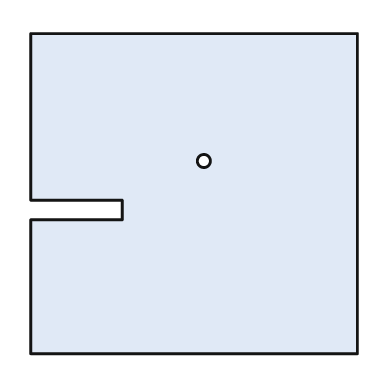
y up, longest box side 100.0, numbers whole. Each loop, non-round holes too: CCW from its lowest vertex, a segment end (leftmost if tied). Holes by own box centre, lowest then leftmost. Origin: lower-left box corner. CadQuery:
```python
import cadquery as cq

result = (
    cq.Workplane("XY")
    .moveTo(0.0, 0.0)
    .lineTo(100.0, 0.0)
    .lineTo(100.0, 98.0)
    .lineTo(0.0, 98.0)
    .lineTo(0.0, 47.0)
    .lineTo(28.0, 47.0)
    .lineTo(28.0, 41.0)
    .lineTo(0.0, 41.0)
    .close()
    .moveTo(53.0, 59.0)
    .circle(2.0)
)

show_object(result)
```